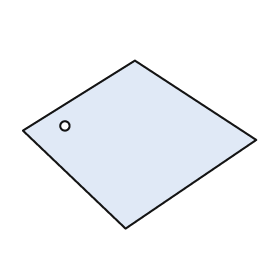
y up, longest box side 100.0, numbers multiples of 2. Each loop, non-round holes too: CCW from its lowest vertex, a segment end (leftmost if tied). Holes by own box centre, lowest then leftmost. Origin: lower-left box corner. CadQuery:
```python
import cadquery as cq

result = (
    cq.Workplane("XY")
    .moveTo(44.0, 0.0)
    .lineTo(100.0, 38.0)
    .lineTo(48.0, 72.0)
    .lineTo(0.0, 42.0)
    .close()
    .moveTo(18.0, 44.0)
    .circle(2.0)
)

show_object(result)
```